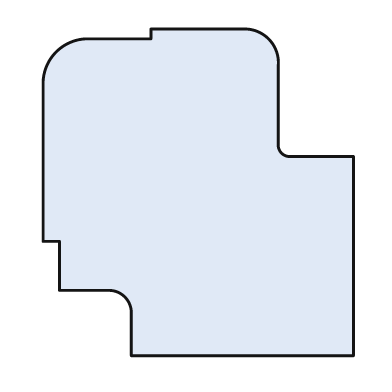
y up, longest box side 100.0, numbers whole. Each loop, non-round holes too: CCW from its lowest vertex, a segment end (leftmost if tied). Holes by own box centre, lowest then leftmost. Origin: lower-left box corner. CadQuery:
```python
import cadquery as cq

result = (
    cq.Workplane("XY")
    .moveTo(27.0, 0.0)
    .lineTo(95.0, 0.0)
    .lineTo(95.0, 61.0)
    .lineTo(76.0, 61.0)
    .threePointArc((73.0, 62.0), (72.0, 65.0))
    .lineTo(72.0, 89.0)
    .threePointArc((69.0, 97.0), (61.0, 100.0))
    .lineTo(33.0, 100.0)
    .lineTo(33.0, 97.0)
    .lineTo(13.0, 97.0)
    .threePointArc((4.0, 93.0), (0.0, 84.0))
    .lineTo(0.0, 35.0)
    .lineTo(5.0, 35.0)
    .lineTo(5.0, 20.0)
    .lineTo(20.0, 20.0)
    .threePointArc((25.0, 18.0), (27.0, 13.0))
    .close()
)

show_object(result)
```